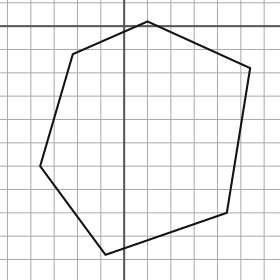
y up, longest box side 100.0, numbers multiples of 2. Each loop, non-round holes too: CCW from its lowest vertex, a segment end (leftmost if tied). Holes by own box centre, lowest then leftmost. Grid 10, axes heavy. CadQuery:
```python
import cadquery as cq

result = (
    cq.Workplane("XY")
    .moveTo(-8.0, -98.0)
    .lineTo(44.0, -80.0)
    .lineTo(54.0, -18.0)
    .lineTo(10.0, 2.0)
    .lineTo(-22.0, -12.0)
    .lineTo(-36.0, -60.0)
    .close()
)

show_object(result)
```